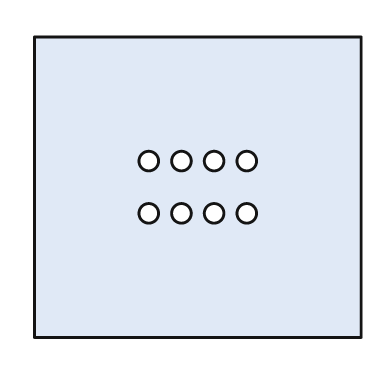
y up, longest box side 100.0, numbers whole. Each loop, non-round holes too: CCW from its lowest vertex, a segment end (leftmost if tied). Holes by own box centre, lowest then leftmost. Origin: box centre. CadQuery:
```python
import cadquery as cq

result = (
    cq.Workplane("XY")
    .moveTo(-50.0, -46.0)
    .lineTo(50.0, -46.0)
    .lineTo(50.0, 46.0)
    .lineTo(-50.0, 46.0)
    .close()
    .moveTo(-15.0, -8.0)
    .circle(3.0)
    .moveTo(-5.0, -8.0)
    .circle(3.0)
    .moveTo(5.0, -8.0)
    .circle(3.0)
    .moveTo(15.0, -8.0)
    .circle(3.0)
    .moveTo(-15.0, 8.0)
    .circle(3.0)
    .moveTo(-5.0, 8.0)
    .circle(3.0)
    .moveTo(5.0, 8.0)
    .circle(3.0)
    .moveTo(15.0, 8.0)
    .circle(3.0)
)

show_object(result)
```